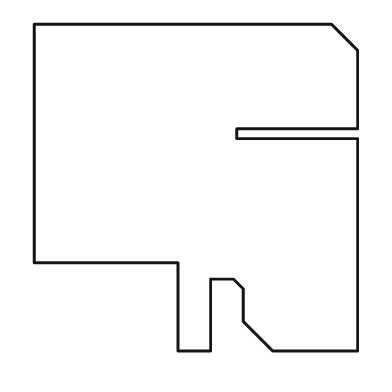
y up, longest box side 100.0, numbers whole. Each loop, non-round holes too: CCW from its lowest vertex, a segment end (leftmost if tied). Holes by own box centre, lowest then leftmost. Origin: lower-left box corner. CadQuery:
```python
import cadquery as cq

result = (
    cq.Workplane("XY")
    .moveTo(44.0, 0.0)
    .lineTo(54.0, 0.0)
    .lineTo(54.0, 22.0)
    .lineTo(61.0, 22.0)
    .lineTo(64.0, 19.0)
    .lineTo(64.0, 9.0)
    .lineTo(73.0, 0.0)
    .lineTo(99.0, 0.0)
    .lineTo(99.0, 65.0)
    .lineTo(62.0, 65.0)
    .lineTo(62.0, 68.0)
    .lineTo(99.0, 68.0)
    .lineTo(99.0, 92.0)
    .lineTo(91.0, 100.0)
    .lineTo(0.0, 100.0)
    .lineTo(0.0, 27.0)
    .lineTo(44.0, 27.0)
    .close()
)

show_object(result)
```